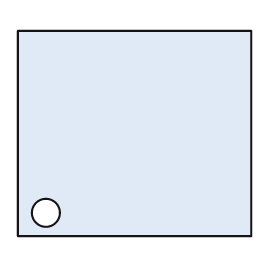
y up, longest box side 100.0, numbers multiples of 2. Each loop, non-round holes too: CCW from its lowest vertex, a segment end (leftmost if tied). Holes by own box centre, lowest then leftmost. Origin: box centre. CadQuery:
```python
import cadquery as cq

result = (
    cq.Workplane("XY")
    .moveTo(-50.0, -44.0)
    .lineTo(50.0, -44.0)
    .lineTo(50.0, 44.0)
    .lineTo(-50.0, 44.0)
    .close()
    .moveTo(-38.0, -34.0)
    .circle(6.0)
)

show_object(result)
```